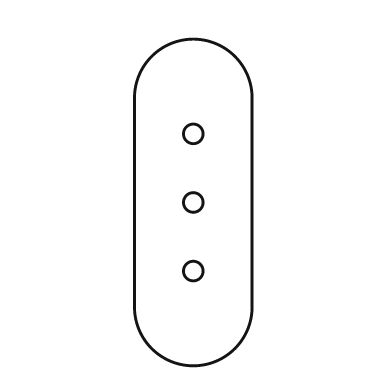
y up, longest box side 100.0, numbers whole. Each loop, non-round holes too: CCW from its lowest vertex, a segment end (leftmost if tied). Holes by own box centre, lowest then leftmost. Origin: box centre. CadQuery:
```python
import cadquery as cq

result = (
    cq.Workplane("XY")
    .moveTo(-18.0, -32.0)
    .threePointArc((0.0, -50.0), (18.0, -32.0))
    .lineTo(18.0, 32.0)
    .threePointArc((0.0, 50.0), (-18.0, 32.0))
    .close()
    .moveTo(0.0, -21.0)
    .circle(3.0)
    .moveTo(0.0, 0.0)
    .circle(3.0)
    .moveTo(0.0, 21.0)
    .circle(3.0)
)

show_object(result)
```